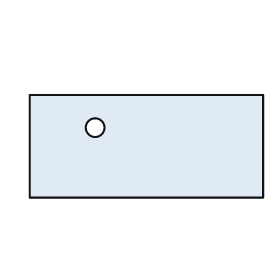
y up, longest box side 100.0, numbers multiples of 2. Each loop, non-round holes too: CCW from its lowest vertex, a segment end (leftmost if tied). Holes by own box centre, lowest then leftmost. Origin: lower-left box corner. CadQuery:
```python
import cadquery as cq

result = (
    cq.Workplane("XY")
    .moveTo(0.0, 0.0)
    .lineTo(100.0, 0.0)
    .lineTo(100.0, 44.0)
    .lineTo(0.0, 44.0)
    .close()
    .moveTo(28.0, 30.0)
    .circle(4.0)
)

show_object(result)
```